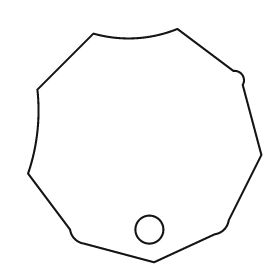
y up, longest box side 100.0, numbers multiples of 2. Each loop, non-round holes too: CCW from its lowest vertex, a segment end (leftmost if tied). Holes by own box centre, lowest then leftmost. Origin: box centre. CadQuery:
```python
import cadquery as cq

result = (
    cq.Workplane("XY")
    .moveTo(4.0, -50.0)
    .lineTo(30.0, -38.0)
    .threePointArc((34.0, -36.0), (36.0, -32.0))
    .lineTo(50.0, -4.0)
    .lineTo(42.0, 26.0)
    .threePointArc((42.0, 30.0), (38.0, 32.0))
    .lineTo(14.0, 50.0)
    .threePointArc((-4.0, 46.0), (-22.0, 48.0))
    .lineTo(-46.0, 24.0)
    .threePointArc((-46.0, 6.0), (-50.0, -12.0))
    .lineTo(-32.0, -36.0)
    .threePointArc((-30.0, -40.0), (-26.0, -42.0))
    .close()
    .moveTo(2.0, -36.0)
    .circle(6.0)
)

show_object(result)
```